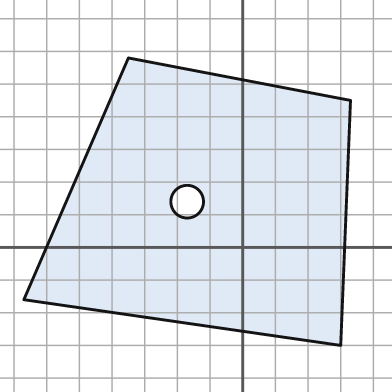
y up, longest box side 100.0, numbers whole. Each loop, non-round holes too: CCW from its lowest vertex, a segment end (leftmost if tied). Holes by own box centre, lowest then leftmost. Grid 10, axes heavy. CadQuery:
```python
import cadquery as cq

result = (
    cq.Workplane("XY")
    .moveTo(30.0, -30.0)
    .lineTo(33.0, 45.0)
    .lineTo(-35.0, 58.0)
    .lineTo(-67.0, -16.0)
    .close()
    .moveTo(-17.0, 14.0)
    .circle(5.0)
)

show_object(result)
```